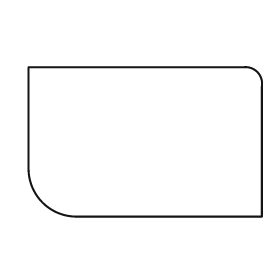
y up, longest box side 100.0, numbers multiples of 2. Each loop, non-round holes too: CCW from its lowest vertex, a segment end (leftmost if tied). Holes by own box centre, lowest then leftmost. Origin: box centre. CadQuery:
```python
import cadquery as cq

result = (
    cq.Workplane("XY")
    .moveTo(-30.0, -32.0)
    .lineTo(50.0, -32.0)
    .lineTo(50.0, 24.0)
    .threePointArc((48.0, 30.0), (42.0, 32.0))
    .lineTo(-50.0, 32.0)
    .lineTo(-50.0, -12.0)
    .threePointArc((-44.0, -26.0), (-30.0, -32.0))
    .close()
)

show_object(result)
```